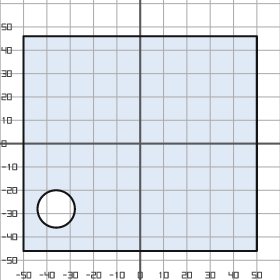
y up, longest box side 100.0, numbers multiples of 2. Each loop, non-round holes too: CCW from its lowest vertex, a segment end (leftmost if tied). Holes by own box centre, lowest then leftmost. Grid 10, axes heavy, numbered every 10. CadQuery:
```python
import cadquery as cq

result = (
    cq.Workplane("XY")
    .moveTo(-50.0, -46.0)
    .lineTo(50.0, -46.0)
    .lineTo(50.0, 46.0)
    .lineTo(-50.0, 46.0)
    .close()
    .moveTo(-36.0, -28.0)
    .circle(8.0)
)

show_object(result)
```